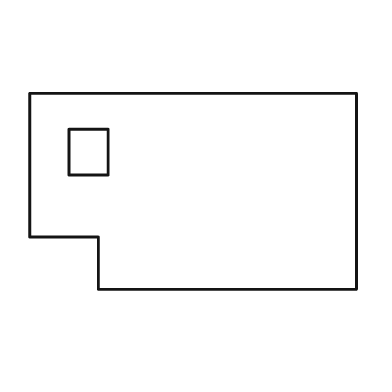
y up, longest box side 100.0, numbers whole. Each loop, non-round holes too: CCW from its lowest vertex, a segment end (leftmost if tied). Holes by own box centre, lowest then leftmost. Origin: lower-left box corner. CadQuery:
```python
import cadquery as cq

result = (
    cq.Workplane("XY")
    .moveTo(21.0, 0.0)
    .lineTo(100.0, 0.0)
    .lineTo(100.0, 60.0)
    .lineTo(0.0, 60.0)
    .lineTo(0.0, 16.0)
    .lineTo(21.0, 16.0)
    .close()
    .moveTo(12.0, 35.0)
    .lineTo(24.0, 35.0)
    .lineTo(24.0, 49.0)
    .lineTo(12.0, 49.0)
    .close()
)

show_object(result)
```